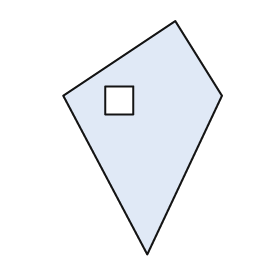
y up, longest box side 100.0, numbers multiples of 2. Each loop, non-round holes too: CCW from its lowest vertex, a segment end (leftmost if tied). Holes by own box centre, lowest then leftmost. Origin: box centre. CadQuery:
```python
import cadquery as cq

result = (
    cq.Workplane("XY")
    .moveTo(2.0, -50.0)
    .lineTo(34.0, 18.0)
    .lineTo(14.0, 50.0)
    .lineTo(-34.0, 18.0)
    .close()
    .moveTo(-16.0, 10.0)
    .lineTo(-4.0, 10.0)
    .lineTo(-4.0, 22.0)
    .lineTo(-16.0, 22.0)
    .close()
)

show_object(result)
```